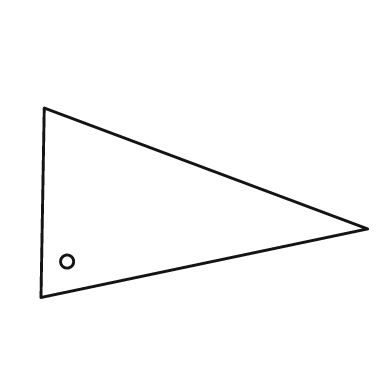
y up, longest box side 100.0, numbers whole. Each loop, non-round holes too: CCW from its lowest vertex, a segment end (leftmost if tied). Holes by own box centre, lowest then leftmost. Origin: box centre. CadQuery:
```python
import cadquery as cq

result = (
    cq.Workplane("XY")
    .moveTo(-50.0, -29.0)
    .lineTo(50.0, -8.0)
    .lineTo(-49.0, 29.0)
    .close()
    .moveTo(-42.0, -18.0)
    .circle(2.0)
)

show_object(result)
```